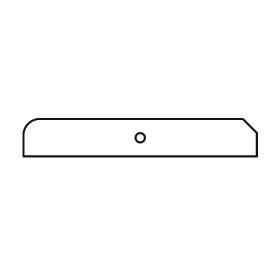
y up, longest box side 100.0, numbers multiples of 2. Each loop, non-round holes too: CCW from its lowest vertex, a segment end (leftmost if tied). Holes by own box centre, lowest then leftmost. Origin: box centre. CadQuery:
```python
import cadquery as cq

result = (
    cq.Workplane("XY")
    .moveTo(-50.0, -8.0)
    .lineTo(50.0, -8.0)
    .lineTo(50.0, 2.0)
    .lineTo(44.0, 8.0)
    .lineTo(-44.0, 8.0)
    .threePointArc((-48.0, 6.0), (-50.0, 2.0))
    .close()
    .moveTo(0.0, 0.0)
    .circle(2.0)
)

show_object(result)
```